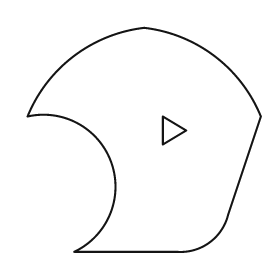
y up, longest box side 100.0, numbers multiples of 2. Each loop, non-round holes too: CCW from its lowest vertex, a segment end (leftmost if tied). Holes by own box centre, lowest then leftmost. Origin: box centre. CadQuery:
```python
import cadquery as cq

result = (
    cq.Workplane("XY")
    .moveTo(-30.0, -48.0)
    .lineTo(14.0, -48.0)
    .threePointArc((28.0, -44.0), (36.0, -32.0))
    .lineTo(50.0, 10.0)
    .threePointArc((30.0, 36.0), (0.0, 48.0))
    .threePointArc((-30.0, 36.0), (-50.0, 10.0))
    .threePointArc((-14.0, -10.0), (-30.0, -48.0))
    .close()
    .moveTo(8.0, -2.0)
    .lineTo(18.0, 4.0)
    .lineTo(8.0, 10.0)
    .close()
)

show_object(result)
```